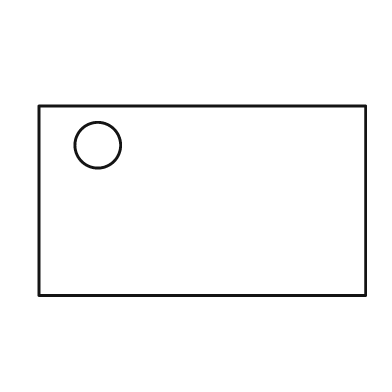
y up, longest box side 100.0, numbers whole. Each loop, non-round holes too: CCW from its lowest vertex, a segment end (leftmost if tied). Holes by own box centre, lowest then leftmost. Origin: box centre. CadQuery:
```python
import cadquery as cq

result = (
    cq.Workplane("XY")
    .moveTo(-50.0, -29.0)
    .lineTo(50.0, -29.0)
    .lineTo(50.0, 29.0)
    .lineTo(-50.0, 29.0)
    .close()
    .moveTo(-32.0, 17.0)
    .circle(7.0)
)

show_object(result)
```